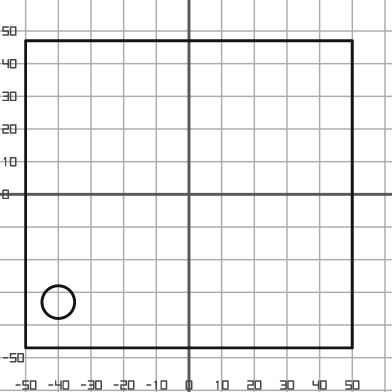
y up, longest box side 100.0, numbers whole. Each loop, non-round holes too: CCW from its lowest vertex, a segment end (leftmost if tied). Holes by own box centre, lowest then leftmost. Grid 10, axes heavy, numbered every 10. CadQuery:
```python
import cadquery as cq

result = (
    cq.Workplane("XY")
    .moveTo(-50.0, -47.0)
    .lineTo(50.0, -47.0)
    .lineTo(50.0, 47.0)
    .lineTo(-50.0, 47.0)
    .close()
    .moveTo(-40.0, -33.0)
    .circle(5.0)
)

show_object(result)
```